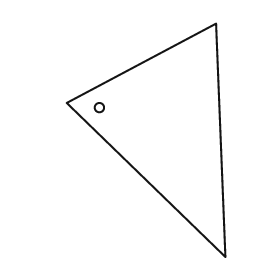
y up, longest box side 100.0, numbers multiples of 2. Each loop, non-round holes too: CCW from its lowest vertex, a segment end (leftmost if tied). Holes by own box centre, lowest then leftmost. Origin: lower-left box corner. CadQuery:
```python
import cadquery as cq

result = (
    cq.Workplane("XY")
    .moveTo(68.0, 0.0)
    .lineTo(64.0, 100.0)
    .lineTo(0.0, 66.0)
    .close()
    .moveTo(14.0, 64.0)
    .circle(2.0)
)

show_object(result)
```